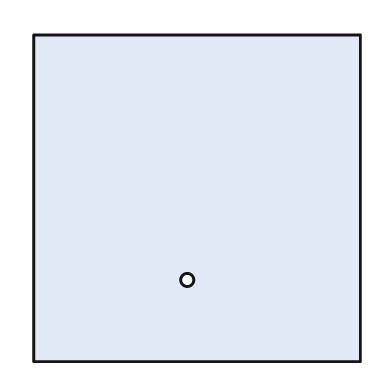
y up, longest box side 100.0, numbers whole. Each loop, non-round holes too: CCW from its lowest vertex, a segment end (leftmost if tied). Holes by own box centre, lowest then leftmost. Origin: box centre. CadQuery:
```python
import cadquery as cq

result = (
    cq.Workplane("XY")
    .moveTo(-50.0, -50.0)
    .lineTo(50.0, -50.0)
    .lineTo(50.0, 50.0)
    .lineTo(-50.0, 50.0)
    .close()
    .moveTo(-3.0, -25.0)
    .circle(2.0)
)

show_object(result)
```